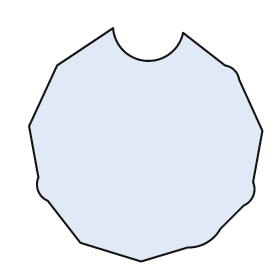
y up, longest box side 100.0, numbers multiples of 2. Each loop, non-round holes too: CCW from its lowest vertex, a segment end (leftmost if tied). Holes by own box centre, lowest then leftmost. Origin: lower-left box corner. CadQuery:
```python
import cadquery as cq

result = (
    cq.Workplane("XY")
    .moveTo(48.0, 0.0)
    .lineTo(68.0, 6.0)
    .threePointArc((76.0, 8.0), (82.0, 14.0))
    .lineTo(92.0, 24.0)
    .threePointArc((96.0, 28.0), (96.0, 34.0))
    .lineTo(100.0, 56.0)
    .lineTo(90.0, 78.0)
    .threePointArc((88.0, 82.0), (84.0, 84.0))
    .lineTo(66.0, 98.0)
    .threePointArc((50.0, 86.0), (36.0, 100.0))
    .lineTo(12.0, 84.0)
    .lineTo(0.0, 58.0)
    .lineTo(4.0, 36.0)
    .threePointArc((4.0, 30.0), (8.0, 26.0))
    .lineTo(22.0, 8.0)
    .close()
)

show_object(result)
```